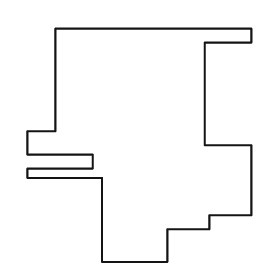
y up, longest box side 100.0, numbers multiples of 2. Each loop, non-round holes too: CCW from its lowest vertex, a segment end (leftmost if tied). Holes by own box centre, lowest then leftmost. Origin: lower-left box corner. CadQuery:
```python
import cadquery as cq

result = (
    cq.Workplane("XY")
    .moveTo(32.0, 0.0)
    .lineTo(60.0, 0.0)
    .lineTo(60.0, 14.0)
    .lineTo(78.0, 14.0)
    .lineTo(78.0, 20.0)
    .lineTo(96.0, 20.0)
    .lineTo(96.0, 50.0)
    .lineTo(76.0, 50.0)
    .lineTo(76.0, 94.0)
    .lineTo(96.0, 94.0)
    .lineTo(96.0, 100.0)
    .lineTo(12.0, 100.0)
    .lineTo(12.0, 56.0)
    .lineTo(0.0, 56.0)
    .lineTo(0.0, 46.0)
    .lineTo(28.0, 46.0)
    .lineTo(28.0, 40.0)
    .lineTo(0.0, 40.0)
    .lineTo(0.0, 36.0)
    .lineTo(32.0, 36.0)
    .close()
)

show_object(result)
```